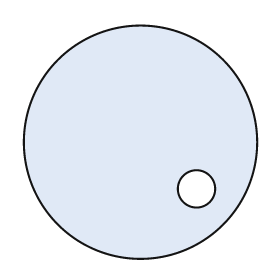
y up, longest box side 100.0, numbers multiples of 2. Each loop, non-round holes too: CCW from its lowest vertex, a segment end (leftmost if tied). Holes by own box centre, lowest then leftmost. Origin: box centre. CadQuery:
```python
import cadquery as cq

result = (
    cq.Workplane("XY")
    .moveTo(0.0, 0.0)
    .circle(50.0)
    .moveTo(24.0, -20.0)
    .circle(8.0)
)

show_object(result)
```